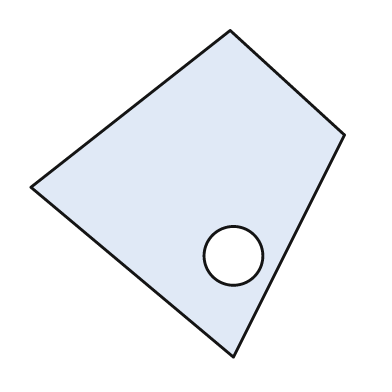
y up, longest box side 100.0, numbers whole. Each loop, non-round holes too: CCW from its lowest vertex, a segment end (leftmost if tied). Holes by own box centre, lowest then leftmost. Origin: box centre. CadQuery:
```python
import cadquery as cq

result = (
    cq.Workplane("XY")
    .moveTo(14.0, -50.0)
    .lineTo(48.0, 18.0)
    .lineTo(13.0, 50.0)
    .lineTo(-48.0, 2.0)
    .close()
    .moveTo(14.0, -19.0)
    .circle(9.0)
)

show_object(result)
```